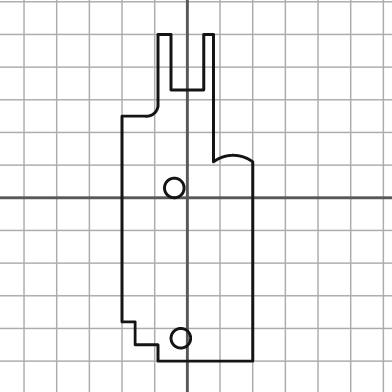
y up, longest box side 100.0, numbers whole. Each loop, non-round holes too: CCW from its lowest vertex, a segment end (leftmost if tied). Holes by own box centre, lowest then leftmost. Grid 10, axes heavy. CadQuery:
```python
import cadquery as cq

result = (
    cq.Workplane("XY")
    .moveTo(-9.0, -50.0)
    .lineTo(20.0, -50.0)
    .lineTo(20.0, 11.0)
    .threePointArc((14.0, 13.0), (8.0, 11.0))
    .lineTo(8.0, 50.0)
    .lineTo(5.0, 50.0)
    .lineTo(5.0, 33.0)
    .lineTo(-5.0, 33.0)
    .lineTo(-5.0, 50.0)
    .lineTo(-9.0, 50.0)
    .lineTo(-9.0, 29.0)
    .threePointArc((-10.0, 26.0), (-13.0, 25.0))
    .lineTo(-20.0, 25.0)
    .lineTo(-20.0, -38.0)
    .lineTo(-16.0, -38.0)
    .lineTo(-16.0, -45.0)
    .lineTo(-9.0, -45.0)
    .close()
    .moveTo(-2.0, -43.0)
    .circle(3.0)
    .moveTo(-4.0, 3.0)
    .circle(3.0)
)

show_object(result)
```